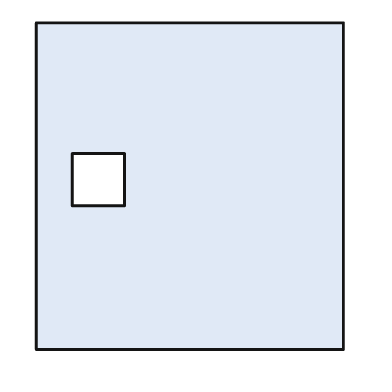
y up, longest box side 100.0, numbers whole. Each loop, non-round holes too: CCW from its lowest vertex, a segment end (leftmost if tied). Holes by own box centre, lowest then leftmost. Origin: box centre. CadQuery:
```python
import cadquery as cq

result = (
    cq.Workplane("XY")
    .moveTo(-47.0, -50.0)
    .lineTo(47.0, -50.0)
    .lineTo(47.0, 50.0)
    .lineTo(-47.0, 50.0)
    .close()
    .moveTo(-36.0, -6.0)
    .lineTo(-20.0, -6.0)
    .lineTo(-20.0, 10.0)
    .lineTo(-36.0, 10.0)
    .close()
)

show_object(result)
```